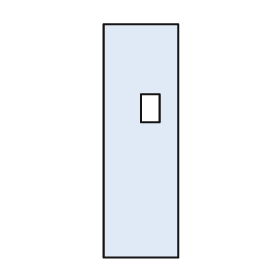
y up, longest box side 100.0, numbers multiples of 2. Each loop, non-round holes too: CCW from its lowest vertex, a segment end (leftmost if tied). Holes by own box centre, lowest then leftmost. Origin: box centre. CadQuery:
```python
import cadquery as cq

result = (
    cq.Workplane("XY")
    .moveTo(-16.0, -50.0)
    .lineTo(16.0, -50.0)
    .lineTo(16.0, 50.0)
    .lineTo(-16.0, 50.0)
    .close()
    .moveTo(0.0, 8.0)
    .lineTo(8.0, 8.0)
    .lineTo(8.0, 20.0)
    .lineTo(0.0, 20.0)
    .close()
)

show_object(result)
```